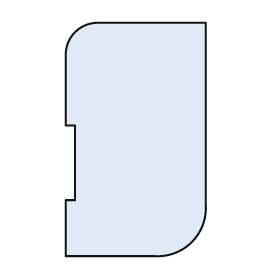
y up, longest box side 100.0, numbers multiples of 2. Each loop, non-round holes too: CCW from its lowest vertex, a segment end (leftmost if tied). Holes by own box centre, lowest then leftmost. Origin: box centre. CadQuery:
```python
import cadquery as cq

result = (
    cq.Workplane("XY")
    .moveTo(-30.0, -50.0)
    .lineTo(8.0, -50.0)
    .threePointArc((24.0, -44.0), (30.0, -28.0))
    .lineTo(30.0, 50.0)
    .lineTo(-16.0, 50.0)
    .threePointArc((-26.0, 46.0), (-30.0, 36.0))
    .lineTo(-30.0, 6.0)
    .lineTo(-26.0, 6.0)
    .lineTo(-26.0, -26.0)
    .lineTo(-30.0, -26.0)
    .close()
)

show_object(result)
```